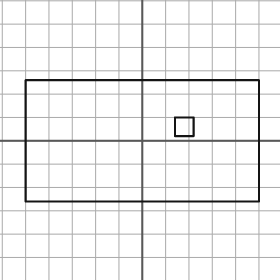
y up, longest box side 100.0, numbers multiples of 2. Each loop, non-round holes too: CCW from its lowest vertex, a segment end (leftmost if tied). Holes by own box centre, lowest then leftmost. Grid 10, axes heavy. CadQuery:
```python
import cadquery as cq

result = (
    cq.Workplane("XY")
    .moveTo(-50.0, -26.0)
    .lineTo(50.0, -26.0)
    .lineTo(50.0, 26.0)
    .lineTo(-50.0, 26.0)
    .close()
    .moveTo(14.0, 2.0)
    .lineTo(22.0, 2.0)
    .lineTo(22.0, 10.0)
    .lineTo(14.0, 10.0)
    .close()
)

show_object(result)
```